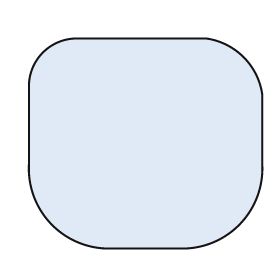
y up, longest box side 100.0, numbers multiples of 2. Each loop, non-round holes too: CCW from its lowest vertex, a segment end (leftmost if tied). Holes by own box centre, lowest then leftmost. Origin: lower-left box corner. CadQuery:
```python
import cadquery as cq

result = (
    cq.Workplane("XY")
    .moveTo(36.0, 0.0)
    .lineTo(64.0, 0.0)
    .threePointArc((90.0, 10.0), (100.0, 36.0))
    .lineTo(100.0, 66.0)
    .threePointArc((92.0, 82.0), (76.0, 90.0))
    .lineTo(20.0, 90.0)
    .threePointArc((6.0, 84.0), (0.0, 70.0))
    .lineTo(0.0, 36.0)
    .threePointArc((10.0, 10.0), (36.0, 0.0))
    .close()
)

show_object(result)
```